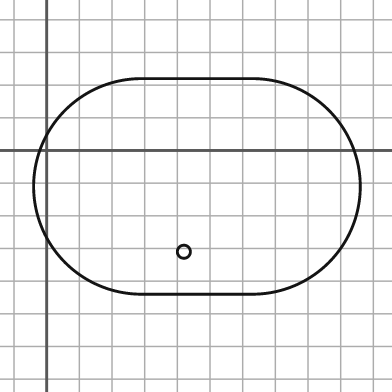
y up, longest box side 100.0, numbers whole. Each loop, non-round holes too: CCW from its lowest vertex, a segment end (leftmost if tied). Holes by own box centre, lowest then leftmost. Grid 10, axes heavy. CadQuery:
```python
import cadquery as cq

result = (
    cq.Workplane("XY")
    .moveTo(29.0, -44.0)
    .lineTo(63.0, -44.0)
    .threePointArc((96.0, -11.0), (63.0, 22.0))
    .lineTo(29.0, 22.0)
    .threePointArc((-4.0, -11.0), (29.0, -44.0))
    .close()
    .moveTo(42.0, -31.0)
    .circle(2.0)
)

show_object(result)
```